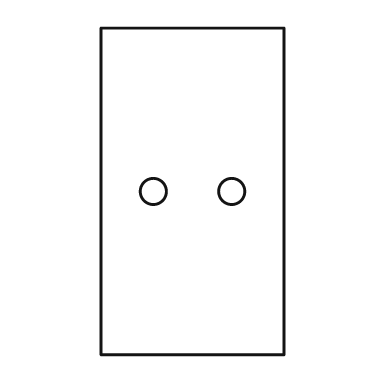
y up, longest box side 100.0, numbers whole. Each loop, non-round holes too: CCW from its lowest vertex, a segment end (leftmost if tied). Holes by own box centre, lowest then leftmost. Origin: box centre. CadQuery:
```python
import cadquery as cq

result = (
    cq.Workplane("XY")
    .moveTo(-28.0, -50.0)
    .lineTo(28.0, -50.0)
    .lineTo(28.0, 50.0)
    .lineTo(-28.0, 50.0)
    .close()
    .moveTo(-12.0, 0.0)
    .circle(4.0)
    .moveTo(12.0, 0.0)
    .circle(4.0)
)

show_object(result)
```